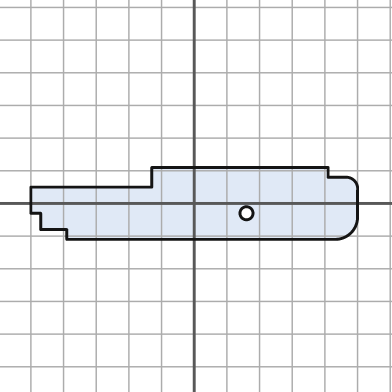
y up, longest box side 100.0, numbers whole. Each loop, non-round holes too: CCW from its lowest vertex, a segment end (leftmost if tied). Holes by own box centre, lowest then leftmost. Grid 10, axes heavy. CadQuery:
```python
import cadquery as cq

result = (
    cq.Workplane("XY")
    .moveTo(-39.0, -11.0)
    .lineTo(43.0, -11.0)
    .threePointArc((48.0, -9.0), (50.0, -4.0))
    .lineTo(50.0, 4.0)
    .threePointArc((49.0, 7.0), (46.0, 8.0))
    .lineTo(41.0, 8.0)
    .lineTo(41.0, 11.0)
    .lineTo(-13.0, 11.0)
    .lineTo(-13.0, 5.0)
    .lineTo(-50.0, 5.0)
    .lineTo(-50.0, -3.0)
    .lineTo(-47.0, -3.0)
    .lineTo(-47.0, -8.0)
    .lineTo(-39.0, -8.0)
    .close()
    .moveTo(16.0, -3.0)
    .circle(2.0)
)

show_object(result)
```